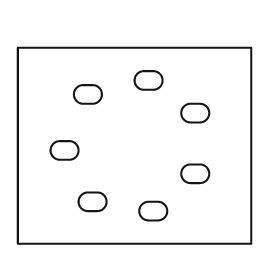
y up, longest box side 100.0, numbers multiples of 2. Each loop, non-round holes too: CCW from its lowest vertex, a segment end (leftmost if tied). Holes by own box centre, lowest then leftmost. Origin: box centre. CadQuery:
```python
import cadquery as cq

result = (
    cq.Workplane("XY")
    .moveTo(-50.0, -42.0)
    .lineTo(50.0, -42.0)
    .lineTo(50.0, 42.0)
    .lineTo(-50.0, 42.0)
    .close()
    .moveTo(6.0, -32.0)
    .lineTo(10.0, -32.0)
    .threePointArc((14.0, -28.0), (10.0, -24.0))
    .lineTo(6.0, -24.0)
    .threePointArc((2.0, -28.0), (6.0, -32.0))
    .close()
    .moveTo(-20.0, -28.0)
    .lineTo(-16.0, -28.0)
    .threePointArc((-12.0, -24.0), (-16.0, -20.0))
    .lineTo(-20.0, -20.0)
    .threePointArc((-24.0, -24.0), (-20.0, -28.0))
    .close()
    .moveTo(24.0, -16.0)
    .lineTo(28.0, -16.0)
    .threePointArc((32.0, -12.0), (28.0, -8.0))
    .lineTo(24.0, -8.0)
    .threePointArc((20.0, -12.0), (24.0, -16.0))
    .close()
    .moveTo(-32.0, -6.0)
    .lineTo(-28.0, -6.0)
    .threePointArc((-24.0, -2.0), (-28.0, 2.0))
    .lineTo(-32.0, 2.0)
    .threePointArc((-36.0, -2.0), (-32.0, -6.0))
    .close()
    .moveTo(24.0, 10.0)
    .lineTo(28.0, 10.0)
    .threePointArc((32.0, 14.0), (28.0, 18.0))
    .lineTo(24.0, 18.0)
    .threePointArc((20.0, 14.0), (24.0, 10.0))
    .close()
    .moveTo(-22.0, 18.0)
    .lineTo(-18.0, 18.0)
    .threePointArc((-14.0, 22.0), (-18.0, 26.0))
    .lineTo(-22.0, 26.0)
    .threePointArc((-26.0, 22.0), (-22.0, 18.0))
    .close()
    .moveTo(4.0, 24.0)
    .lineTo(8.0, 24.0)
    .threePointArc((12.0, 28.0), (8.0, 32.0))
    .lineTo(4.0, 32.0)
    .threePointArc((0.0, 28.0), (4.0, 24.0))
    .close()
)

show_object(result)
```